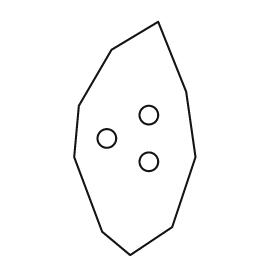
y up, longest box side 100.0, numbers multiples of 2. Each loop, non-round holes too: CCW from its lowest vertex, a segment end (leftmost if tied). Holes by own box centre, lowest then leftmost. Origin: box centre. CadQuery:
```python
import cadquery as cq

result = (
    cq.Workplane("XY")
    .moveTo(-2.0, -50.0)
    .lineTo(16.0, -38.0)
    .lineTo(26.0, -8.0)
    .lineTo(22.0, 20.0)
    .lineTo(10.0, 50.0)
    .lineTo(-10.0, 38.0)
    .lineTo(-24.0, 14.0)
    .lineTo(-26.0, -8.0)
    .lineTo(-14.0, -40.0)
    .close()
    .moveTo(6.0, -10.0)
    .circle(4.0)
    .moveTo(-12.0, 0.0)
    .circle(4.0)
    .moveTo(6.0, 10.0)
    .circle(4.0)
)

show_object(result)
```